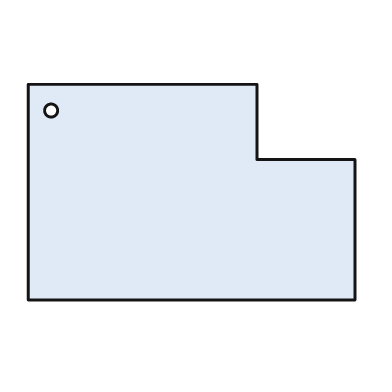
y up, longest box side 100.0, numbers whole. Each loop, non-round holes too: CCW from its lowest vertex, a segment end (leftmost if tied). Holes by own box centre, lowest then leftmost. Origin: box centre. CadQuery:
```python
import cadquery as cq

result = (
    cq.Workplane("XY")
    .moveTo(-50.0, -33.0)
    .lineTo(50.0, -33.0)
    .lineTo(50.0, 10.0)
    .lineTo(20.0, 10.0)
    .lineTo(20.0, 33.0)
    .lineTo(-50.0, 33.0)
    .close()
    .moveTo(-43.0, 25.0)
    .circle(2.0)
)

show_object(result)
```